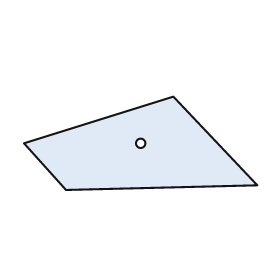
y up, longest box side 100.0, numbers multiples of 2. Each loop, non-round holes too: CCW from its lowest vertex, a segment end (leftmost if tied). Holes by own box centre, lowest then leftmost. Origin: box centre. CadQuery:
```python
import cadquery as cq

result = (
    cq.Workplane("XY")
    .moveTo(-32.0, -20.0)
    .lineTo(50.0, -18.0)
    .lineTo(14.0, 20.0)
    .lineTo(-50.0, 0.0)
    .close()
    .moveTo(0.0, 0.0)
    .circle(2.0)
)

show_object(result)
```